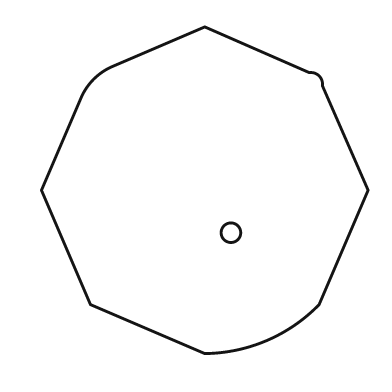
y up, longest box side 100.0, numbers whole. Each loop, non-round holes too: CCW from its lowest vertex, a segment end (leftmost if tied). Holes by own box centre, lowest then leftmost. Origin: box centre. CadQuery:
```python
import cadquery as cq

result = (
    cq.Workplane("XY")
    .moveTo(0.0, -50.0)
    .threePointArc((19.0, -46.0), (35.0, -35.0))
    .lineTo(50.0, 0.0)
    .lineTo(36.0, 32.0)
    .threePointArc((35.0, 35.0), (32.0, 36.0))
    .lineTo(0.0, 50.0)
    .lineTo(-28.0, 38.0)
    .threePointArc((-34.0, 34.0), (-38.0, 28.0))
    .lineTo(-50.0, 0.0)
    .lineTo(-35.0, -35.0)
    .close()
    .moveTo(8.0, -13.0)
    .circle(3.0)
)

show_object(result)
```